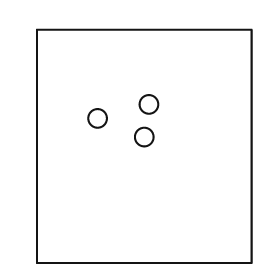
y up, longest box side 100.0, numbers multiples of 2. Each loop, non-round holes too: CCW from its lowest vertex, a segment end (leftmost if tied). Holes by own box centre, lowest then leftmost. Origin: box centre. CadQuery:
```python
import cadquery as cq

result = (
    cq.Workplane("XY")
    .moveTo(-46.0, -50.0)
    .lineTo(46.0, -50.0)
    .lineTo(46.0, 50.0)
    .lineTo(-46.0, 50.0)
    .close()
    .moveTo(0.0, 4.0)
    .circle(4.0)
    .moveTo(-20.0, 12.0)
    .circle(4.0)
    .moveTo(2.0, 18.0)
    .circle(4.0)
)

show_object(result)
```